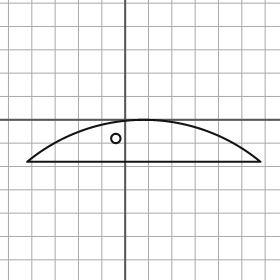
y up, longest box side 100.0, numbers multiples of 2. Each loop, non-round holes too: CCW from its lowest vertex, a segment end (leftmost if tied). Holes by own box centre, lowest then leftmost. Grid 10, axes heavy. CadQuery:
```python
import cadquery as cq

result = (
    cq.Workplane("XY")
    .moveTo(-42.0, -18.0)
    .lineTo(58.0, -18.0)
    .threePointArc((8.0, 0.0), (-42.0, -18.0))
    .close()
    .moveTo(-4.0, -8.0)
    .circle(2.0)
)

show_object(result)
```